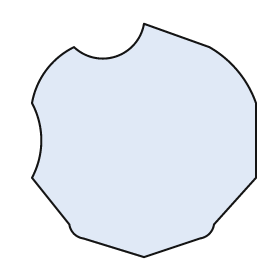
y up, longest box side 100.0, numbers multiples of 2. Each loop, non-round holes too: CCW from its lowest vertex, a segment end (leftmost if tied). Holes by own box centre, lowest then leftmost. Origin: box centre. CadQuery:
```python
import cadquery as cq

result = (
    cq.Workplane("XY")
    .moveTo(0.0, -50.0)
    .lineTo(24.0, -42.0)
    .threePointArc((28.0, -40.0), (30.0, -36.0))
    .lineTo(48.0, -16.0)
    .lineTo(48.0, 16.0)
    .threePointArc((40.0, 30.0), (28.0, 40.0))
    .lineTo(0.0, 50.0)
    .threePointArc((-12.0, 36.0), (-30.0, 40.0))
    .threePointArc((-42.0, 30.0), (-48.0, 16.0))
    .threePointArc((-44.0, 0.0), (-48.0, -16.0))
    .lineTo(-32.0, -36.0)
    .threePointArc((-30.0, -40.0), (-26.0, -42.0))
    .close()
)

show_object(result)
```